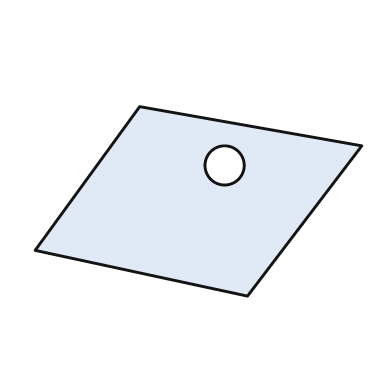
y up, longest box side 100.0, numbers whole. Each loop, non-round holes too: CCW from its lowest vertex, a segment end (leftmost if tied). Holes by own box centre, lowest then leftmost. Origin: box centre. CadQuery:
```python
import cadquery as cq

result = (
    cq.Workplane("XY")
    .moveTo(15.0, -29.0)
    .lineTo(50.0, 17.0)
    .lineTo(-18.0, 29.0)
    .lineTo(-50.0, -15.0)
    .close()
    .moveTo(8.0, 11.0)
    .circle(6.0)
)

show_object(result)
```